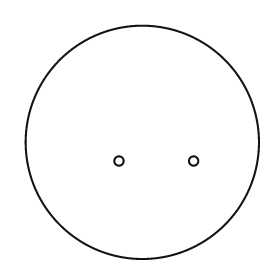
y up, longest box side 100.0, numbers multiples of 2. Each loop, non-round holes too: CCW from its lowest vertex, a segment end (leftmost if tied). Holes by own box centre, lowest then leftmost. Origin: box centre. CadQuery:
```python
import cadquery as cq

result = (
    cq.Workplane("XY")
    .moveTo(0.0, 0.0)
    .circle(50.0)
    .moveTo(-10.0, -8.0)
    .circle(2.0)
    .moveTo(22.0, -8.0)
    .circle(2.0)
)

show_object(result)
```